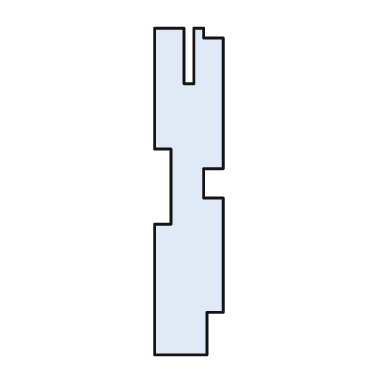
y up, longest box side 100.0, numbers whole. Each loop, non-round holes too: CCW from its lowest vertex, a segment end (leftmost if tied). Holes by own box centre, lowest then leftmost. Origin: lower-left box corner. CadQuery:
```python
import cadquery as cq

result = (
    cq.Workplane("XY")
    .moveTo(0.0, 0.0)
    .lineTo(16.0, 0.0)
    .lineTo(16.0, 13.0)
    .lineTo(21.0, 13.0)
    .lineTo(21.0, 48.0)
    .lineTo(15.0, 48.0)
    .lineTo(15.0, 57.0)
    .lineTo(21.0, 57.0)
    .lineTo(21.0, 97.0)
    .lineTo(15.0, 97.0)
    .lineTo(15.0, 100.0)
    .lineTo(12.0, 100.0)
    .lineTo(12.0, 83.0)
    .lineTo(9.0, 83.0)
    .lineTo(9.0, 100.0)
    .lineTo(0.0, 100.0)
    .lineTo(0.0, 63.0)
    .lineTo(5.0, 63.0)
    .lineTo(5.0, 40.0)
    .lineTo(0.0, 40.0)
    .close()
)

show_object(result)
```